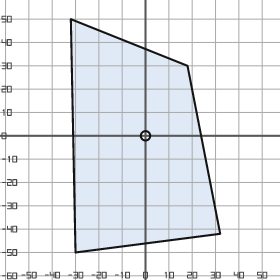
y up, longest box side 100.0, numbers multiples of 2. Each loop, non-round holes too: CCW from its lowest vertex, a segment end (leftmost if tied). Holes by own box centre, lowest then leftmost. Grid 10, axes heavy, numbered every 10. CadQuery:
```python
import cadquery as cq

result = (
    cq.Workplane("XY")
    .moveTo(-30.0, -50.0)
    .lineTo(32.0, -42.0)
    .lineTo(18.0, 30.0)
    .lineTo(-32.0, 50.0)
    .close()
    .moveTo(0.0, 0.0)
    .circle(2.0)
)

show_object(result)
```